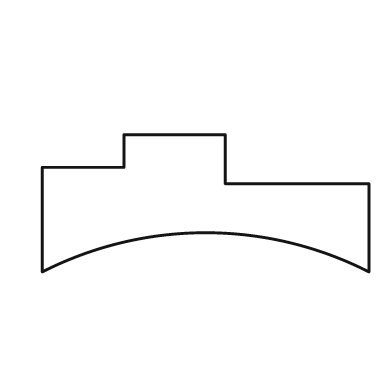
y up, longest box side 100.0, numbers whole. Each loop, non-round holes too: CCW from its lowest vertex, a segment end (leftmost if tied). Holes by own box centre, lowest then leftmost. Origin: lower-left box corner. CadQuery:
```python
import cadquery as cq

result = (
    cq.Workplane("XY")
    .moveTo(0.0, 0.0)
    .threePointArc((50.0, 12.0), (100.0, 0.0))
    .lineTo(100.0, 27.0)
    .lineTo(56.0, 27.0)
    .lineTo(56.0, 42.0)
    .lineTo(25.0, 42.0)
    .lineTo(25.0, 32.0)
    .lineTo(0.0, 32.0)
    .close()
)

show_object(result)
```